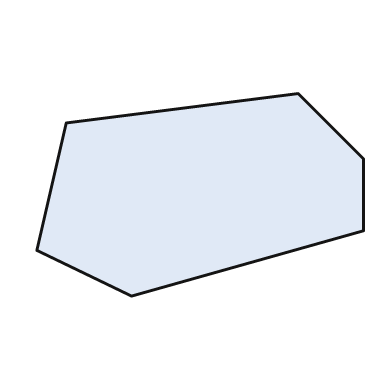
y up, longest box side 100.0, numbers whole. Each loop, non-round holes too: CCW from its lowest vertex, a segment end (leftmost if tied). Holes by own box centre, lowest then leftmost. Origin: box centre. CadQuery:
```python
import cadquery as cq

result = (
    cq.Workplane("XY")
    .moveTo(-21.0, -31.0)
    .lineTo(50.0, -11.0)
    .lineTo(50.0, 11.0)
    .lineTo(30.0, 31.0)
    .lineTo(-41.0, 22.0)
    .lineTo(-50.0, -17.0)
    .close()
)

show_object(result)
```